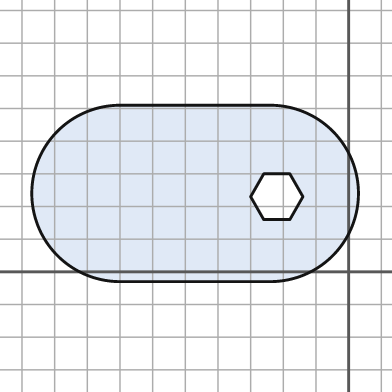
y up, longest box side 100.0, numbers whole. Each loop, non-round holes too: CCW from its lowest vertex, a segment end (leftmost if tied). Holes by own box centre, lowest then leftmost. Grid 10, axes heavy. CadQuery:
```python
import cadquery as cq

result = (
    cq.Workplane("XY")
    .moveTo(-70.0, -3.0)
    .lineTo(-24.0, -3.0)
    .threePointArc((3.0, 24.0), (-24.0, 51.0))
    .lineTo(-70.0, 51.0)
    .threePointArc((-97.0, 24.0), (-70.0, -3.0))
    .close()
    .moveTo(-26.0, 16.0)
    .lineTo(-18.0, 16.0)
    .lineTo(-14.0, 23.0)
    .lineTo(-18.0, 30.0)
    .lineTo(-26.0, 30.0)
    .lineTo(-30.0, 23.0)
    .close()
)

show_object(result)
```